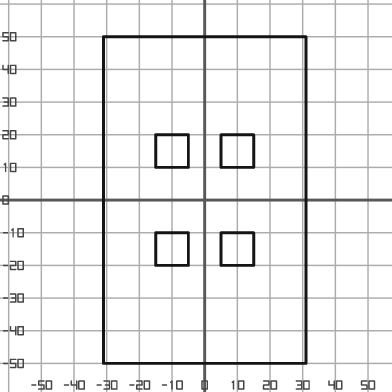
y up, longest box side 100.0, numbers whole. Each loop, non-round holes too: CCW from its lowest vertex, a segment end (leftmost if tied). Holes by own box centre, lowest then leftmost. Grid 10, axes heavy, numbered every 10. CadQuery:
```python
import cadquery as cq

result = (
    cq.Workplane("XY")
    .moveTo(-31.0, -50.0)
    .lineTo(31.0, -50.0)
    .lineTo(31.0, 50.0)
    .lineTo(-31.0, 50.0)
    .close()
    .moveTo(-15.0, -20.0)
    .lineTo(-5.0, -20.0)
    .lineTo(-5.0, -10.0)
    .lineTo(-15.0, -10.0)
    .close()
    .moveTo(5.0, -20.0)
    .lineTo(15.0, -20.0)
    .lineTo(15.0, -10.0)
    .lineTo(5.0, -10.0)
    .close()
    .moveTo(-15.0, 10.0)
    .lineTo(-5.0, 10.0)
    .lineTo(-5.0, 20.0)
    .lineTo(-15.0, 20.0)
    .close()
    .moveTo(5.0, 10.0)
    .lineTo(15.0, 10.0)
    .lineTo(15.0, 20.0)
    .lineTo(5.0, 20.0)
    .close()
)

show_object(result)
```